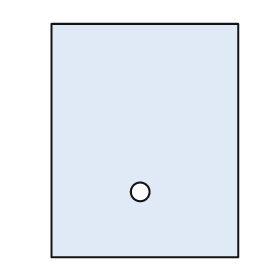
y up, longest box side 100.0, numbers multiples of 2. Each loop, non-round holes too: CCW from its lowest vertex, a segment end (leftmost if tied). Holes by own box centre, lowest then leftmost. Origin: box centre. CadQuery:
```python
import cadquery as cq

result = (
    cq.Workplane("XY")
    .moveTo(-40.0, -50.0)
    .lineTo(40.0, -50.0)
    .lineTo(40.0, 50.0)
    .lineTo(-40.0, 50.0)
    .close()
    .moveTo(-2.0, -22.0)
    .circle(4.0)
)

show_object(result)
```